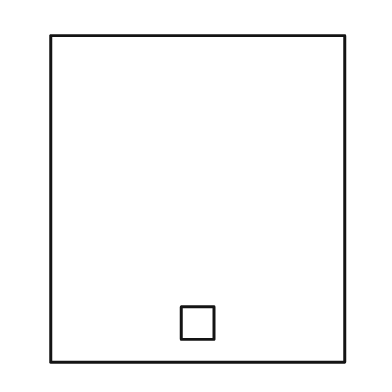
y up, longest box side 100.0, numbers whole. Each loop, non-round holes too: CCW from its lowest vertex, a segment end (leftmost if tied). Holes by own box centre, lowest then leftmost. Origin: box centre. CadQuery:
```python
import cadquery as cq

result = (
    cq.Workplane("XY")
    .moveTo(-45.0, -50.0)
    .lineTo(45.0, -50.0)
    .lineTo(45.0, 50.0)
    .lineTo(-45.0, 50.0)
    .close()
    .moveTo(-5.0, -43.0)
    .lineTo(5.0, -43.0)
    .lineTo(5.0, -33.0)
    .lineTo(-5.0, -33.0)
    .close()
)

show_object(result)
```